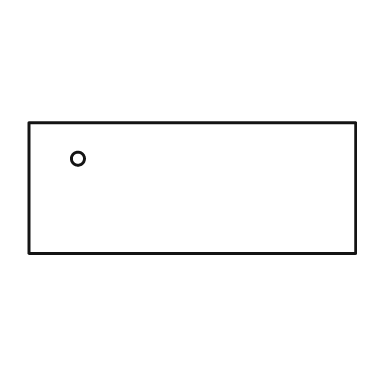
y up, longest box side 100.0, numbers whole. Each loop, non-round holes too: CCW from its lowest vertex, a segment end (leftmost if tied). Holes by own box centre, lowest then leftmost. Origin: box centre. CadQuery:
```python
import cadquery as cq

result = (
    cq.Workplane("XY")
    .moveTo(-50.0, -20.0)
    .lineTo(50.0, -20.0)
    .lineTo(50.0, 20.0)
    .lineTo(-50.0, 20.0)
    .close()
    .moveTo(-35.0, 9.0)
    .circle(2.0)
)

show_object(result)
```